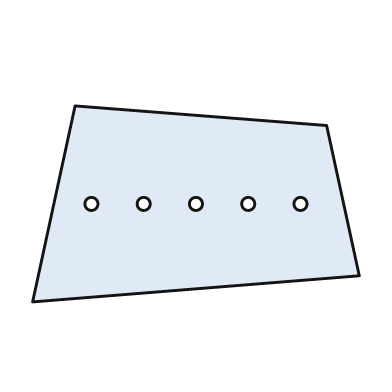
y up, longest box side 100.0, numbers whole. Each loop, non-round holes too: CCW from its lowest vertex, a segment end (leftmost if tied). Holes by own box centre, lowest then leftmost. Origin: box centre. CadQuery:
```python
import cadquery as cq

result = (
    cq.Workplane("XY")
    .moveTo(-50.0, -30.0)
    .lineTo(50.0, -22.0)
    .lineTo(40.0, 24.0)
    .lineTo(-37.0, 30.0)
    .close()
    .moveTo(-32.0, 0.0)
    .circle(2.0)
    .moveTo(-16.0, 0.0)
    .circle(2.0)
    .moveTo(0.0, 0.0)
    .circle(2.0)
    .moveTo(16.0, 0.0)
    .circle(2.0)
    .moveTo(32.0, 0.0)
    .circle(2.0)
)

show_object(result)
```